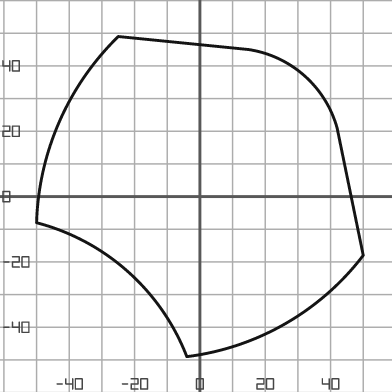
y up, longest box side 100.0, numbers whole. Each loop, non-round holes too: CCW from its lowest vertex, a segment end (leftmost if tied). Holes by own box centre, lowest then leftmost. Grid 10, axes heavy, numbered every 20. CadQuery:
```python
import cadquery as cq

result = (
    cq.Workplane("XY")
    .moveTo(-4.0, -49.0)
    .threePointArc((26.0, -39.0), (50.0, -18.0))
    .lineTo(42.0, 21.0)
    .threePointArc((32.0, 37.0), (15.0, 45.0))
    .lineTo(-25.0, 49.0)
    .threePointArc((-43.0, 23.0), (-50.0, -8.0))
    .threePointArc((-22.0, -23.0), (-4.0, -49.0))
    .close()
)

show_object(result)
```